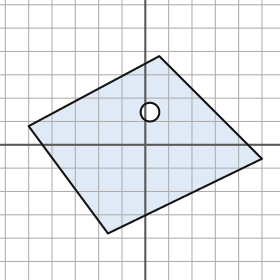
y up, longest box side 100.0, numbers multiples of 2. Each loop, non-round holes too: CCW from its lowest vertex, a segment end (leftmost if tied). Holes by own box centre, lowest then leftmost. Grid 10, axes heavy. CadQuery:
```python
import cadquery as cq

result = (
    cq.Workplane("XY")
    .moveTo(-16.0, -38.0)
    .lineTo(50.0, -6.0)
    .lineTo(6.0, 38.0)
    .lineTo(-50.0, 8.0)
    .close()
    .moveTo(2.0, 14.0)
    .circle(4.0)
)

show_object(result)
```